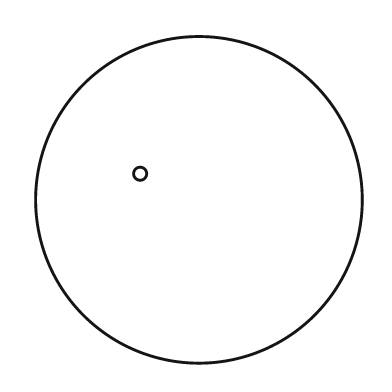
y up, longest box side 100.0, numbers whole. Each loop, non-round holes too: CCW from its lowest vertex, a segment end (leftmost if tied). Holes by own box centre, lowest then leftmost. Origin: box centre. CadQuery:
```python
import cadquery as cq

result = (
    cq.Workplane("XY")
    .moveTo(0.0, 0.0)
    .circle(50.0)
    .moveTo(-18.0, 8.0)
    .circle(2.0)
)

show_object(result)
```